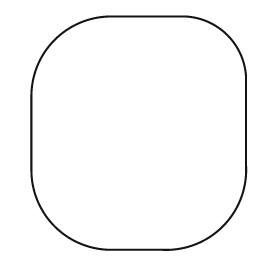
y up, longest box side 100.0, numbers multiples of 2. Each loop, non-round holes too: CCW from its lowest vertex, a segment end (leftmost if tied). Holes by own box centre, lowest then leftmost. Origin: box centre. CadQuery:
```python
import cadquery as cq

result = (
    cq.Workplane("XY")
    .moveTo(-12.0, -50.0)
    .lineTo(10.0, -50.0)
    .threePointArc((36.0, -40.0), (46.0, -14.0))
    .lineTo(46.0, 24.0)
    .threePointArc((38.0, 42.0), (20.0, 50.0))
    .lineTo(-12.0, 50.0)
    .threePointArc((-36.0, 40.0), (-46.0, 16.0))
    .lineTo(-46.0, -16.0)
    .threePointArc((-36.0, -40.0), (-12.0, -50.0))
    .close()
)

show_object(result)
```